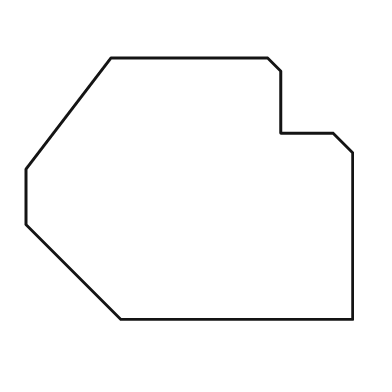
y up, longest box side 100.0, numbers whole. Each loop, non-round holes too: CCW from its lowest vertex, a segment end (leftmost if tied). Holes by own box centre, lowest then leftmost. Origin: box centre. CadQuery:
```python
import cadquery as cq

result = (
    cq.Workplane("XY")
    .moveTo(-21.0, -40.0)
    .lineTo(50.0, -40.0)
    .lineTo(50.0, 11.0)
    .lineTo(44.0, 17.0)
    .lineTo(28.0, 17.0)
    .lineTo(28.0, 36.0)
    .lineTo(24.0, 40.0)
    .lineTo(-24.0, 40.0)
    .lineTo(-50.0, 6.0)
    .lineTo(-50.0, -11.0)
    .close()
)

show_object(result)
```